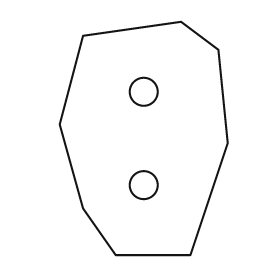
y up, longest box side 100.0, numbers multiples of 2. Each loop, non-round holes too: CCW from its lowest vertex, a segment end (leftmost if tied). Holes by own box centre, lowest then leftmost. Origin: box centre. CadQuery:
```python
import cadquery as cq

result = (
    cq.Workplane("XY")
    .moveTo(-12.0, -50.0)
    .lineTo(20.0, -50.0)
    .lineTo(36.0, -2.0)
    .lineTo(32.0, 38.0)
    .lineTo(16.0, 50.0)
    .lineTo(-26.0, 44.0)
    .lineTo(-36.0, 6.0)
    .lineTo(-26.0, -30.0)
    .close()
    .moveTo(0.0, -20.0)
    .circle(6.0)
    .moveTo(0.0, 20.0)
    .circle(6.0)
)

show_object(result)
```